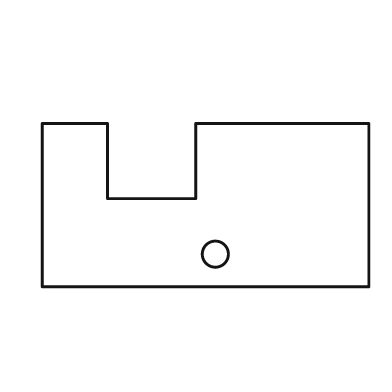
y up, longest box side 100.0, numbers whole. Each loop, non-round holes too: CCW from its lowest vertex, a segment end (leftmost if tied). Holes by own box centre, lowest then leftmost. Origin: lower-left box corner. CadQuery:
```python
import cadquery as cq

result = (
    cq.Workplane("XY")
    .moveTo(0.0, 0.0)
    .lineTo(100.0, 0.0)
    .lineTo(100.0, 50.0)
    .lineTo(47.0, 50.0)
    .lineTo(47.0, 27.0)
    .lineTo(20.0, 27.0)
    .lineTo(20.0, 50.0)
    .lineTo(0.0, 50.0)
    .close()
    .moveTo(53.0, 10.0)
    .circle(4.0)
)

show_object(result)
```